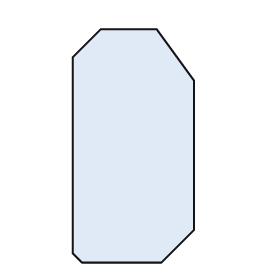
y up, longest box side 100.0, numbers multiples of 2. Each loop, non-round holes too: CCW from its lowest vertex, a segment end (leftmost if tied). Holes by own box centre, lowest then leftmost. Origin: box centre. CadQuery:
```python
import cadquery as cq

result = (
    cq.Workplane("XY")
    .moveTo(-22.0, -50.0)
    .lineTo(12.0, -50.0)
    .lineTo(26.0, -36.0)
    .lineTo(26.0, 28.0)
    .lineTo(10.0, 50.0)
    .lineTo(-14.0, 50.0)
    .lineTo(-26.0, 38.0)
    .lineTo(-26.0, -46.0)
    .close()
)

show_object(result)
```